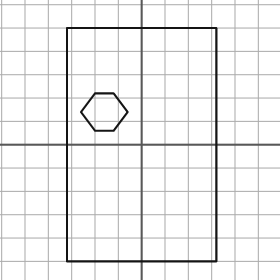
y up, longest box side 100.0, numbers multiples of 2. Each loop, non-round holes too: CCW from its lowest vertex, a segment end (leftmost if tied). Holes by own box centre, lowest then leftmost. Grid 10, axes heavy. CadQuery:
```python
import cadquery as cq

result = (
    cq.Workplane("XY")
    .moveTo(-32.0, -50.0)
    .lineTo(32.0, -50.0)
    .lineTo(32.0, 50.0)
    .lineTo(-32.0, 50.0)
    .close()
    .moveTo(-20.0, 6.0)
    .lineTo(-12.0, 6.0)
    .lineTo(-6.0, 14.0)
    .lineTo(-12.0, 22.0)
    .lineTo(-20.0, 22.0)
    .lineTo(-26.0, 14.0)
    .close()
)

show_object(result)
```